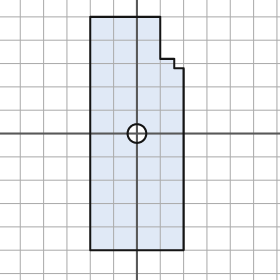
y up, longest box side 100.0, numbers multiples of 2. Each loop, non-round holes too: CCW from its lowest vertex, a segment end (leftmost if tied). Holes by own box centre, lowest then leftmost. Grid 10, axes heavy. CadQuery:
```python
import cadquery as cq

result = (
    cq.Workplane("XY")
    .moveTo(-20.0, -50.0)
    .lineTo(20.0, -50.0)
    .lineTo(20.0, 28.0)
    .lineTo(16.0, 28.0)
    .lineTo(16.0, 32.0)
    .lineTo(10.0, 32.0)
    .lineTo(10.0, 50.0)
    .lineTo(-20.0, 50.0)
    .close()
    .moveTo(0.0, 0.0)
    .circle(4.0)
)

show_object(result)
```